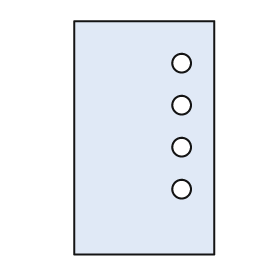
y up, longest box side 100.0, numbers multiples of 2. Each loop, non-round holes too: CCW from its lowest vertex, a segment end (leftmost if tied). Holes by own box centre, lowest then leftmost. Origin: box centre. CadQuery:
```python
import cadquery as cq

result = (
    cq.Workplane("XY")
    .moveTo(-30.0, -50.0)
    .lineTo(30.0, -50.0)
    .lineTo(30.0, 50.0)
    .lineTo(-30.0, 50.0)
    .close()
    .moveTo(16.0, -22.0)
    .circle(4.0)
    .moveTo(16.0, -4.0)
    .circle(4.0)
    .moveTo(16.0, 14.0)
    .circle(4.0)
    .moveTo(16.0, 32.0)
    .circle(4.0)
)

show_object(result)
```